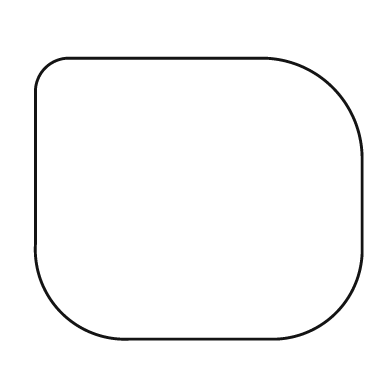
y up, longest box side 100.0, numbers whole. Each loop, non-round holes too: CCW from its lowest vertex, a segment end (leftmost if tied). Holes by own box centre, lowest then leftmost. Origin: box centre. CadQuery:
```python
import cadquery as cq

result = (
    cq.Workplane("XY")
    .moveTo(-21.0, -43.0)
    .lineTo(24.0, -43.0)
    .threePointArc((42.0, -35.0), (50.0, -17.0))
    .lineTo(50.0, 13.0)
    .threePointArc((41.0, 34.0), (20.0, 43.0))
    .lineTo(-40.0, 43.0)
    .threePointArc((-47.0, 40.0), (-50.0, 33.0))
    .lineTo(-50.0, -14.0)
    .threePointArc((-42.0, -35.0), (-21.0, -43.0))
    .close()
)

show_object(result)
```